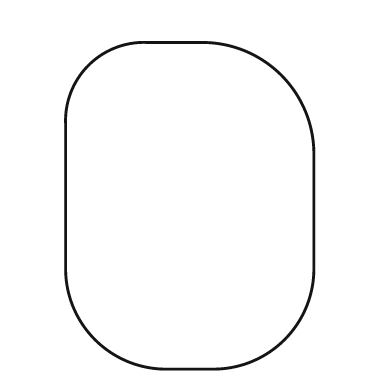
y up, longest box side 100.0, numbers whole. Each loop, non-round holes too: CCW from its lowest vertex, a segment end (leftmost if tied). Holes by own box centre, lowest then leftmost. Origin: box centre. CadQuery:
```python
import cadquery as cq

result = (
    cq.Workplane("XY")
    .moveTo(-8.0, -50.0)
    .lineTo(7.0, -50.0)
    .threePointArc((29.0, -41.0), (38.0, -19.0))
    .lineTo(38.0, 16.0)
    .threePointArc((28.0, 40.0), (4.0, 50.0))
    .lineTo(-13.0, 50.0)
    .threePointArc((-31.0, 43.0), (-38.0, 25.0))
    .lineTo(-38.0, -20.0)
    .threePointArc((-29.0, -41.0), (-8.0, -50.0))
    .close()
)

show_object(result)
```